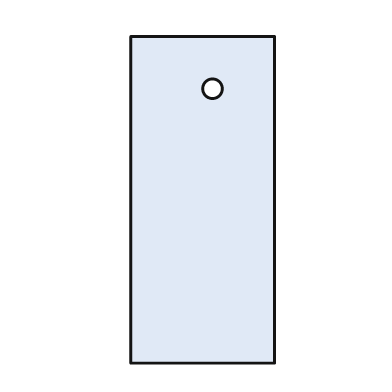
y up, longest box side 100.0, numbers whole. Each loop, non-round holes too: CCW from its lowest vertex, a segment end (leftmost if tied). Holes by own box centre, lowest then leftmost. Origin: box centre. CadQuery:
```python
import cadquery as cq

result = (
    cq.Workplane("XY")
    .moveTo(-22.0, -50.0)
    .lineTo(22.0, -50.0)
    .lineTo(22.0, 50.0)
    .lineTo(-22.0, 50.0)
    .close()
    .moveTo(3.0, 34.0)
    .circle(3.0)
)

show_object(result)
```